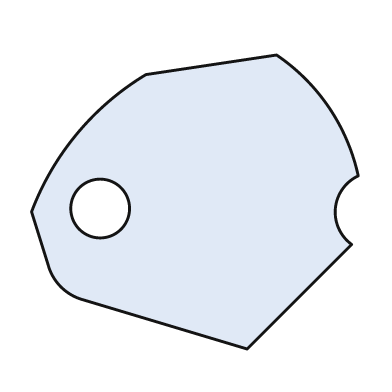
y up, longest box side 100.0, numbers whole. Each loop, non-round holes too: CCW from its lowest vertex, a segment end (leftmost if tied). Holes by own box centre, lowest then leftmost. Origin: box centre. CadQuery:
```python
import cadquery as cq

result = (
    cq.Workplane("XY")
    .moveTo(16.0, -45.0)
    .lineTo(48.0, -13.0)
    .threePointArc((43.0, -2.0), (50.0, 8.0))
    .threePointArc((41.0, 29.0), (25.0, 45.0))
    .lineTo(-15.0, 39.0)
    .threePointArc((-36.0, 21.0), (-50.0, -3.0))
    .lineTo(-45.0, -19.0)
    .threePointArc((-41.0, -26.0), (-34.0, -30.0))
    .close()
    .moveTo(-29.0, -2.0)
    .circle(9.0)
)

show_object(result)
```